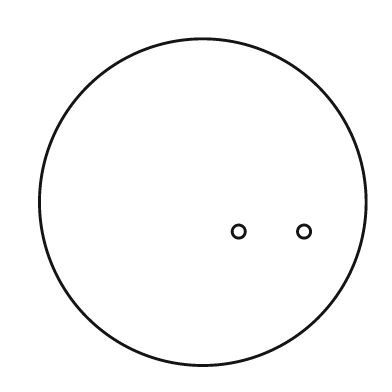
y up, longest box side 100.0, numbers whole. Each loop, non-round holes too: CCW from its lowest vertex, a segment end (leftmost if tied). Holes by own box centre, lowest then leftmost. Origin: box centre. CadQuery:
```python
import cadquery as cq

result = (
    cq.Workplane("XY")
    .moveTo(0.0, 0.0)
    .circle(50.0)
    .moveTo(11.0, -9.0)
    .circle(2.0)
    .moveTo(31.0, -9.0)
    .circle(2.0)
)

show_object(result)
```